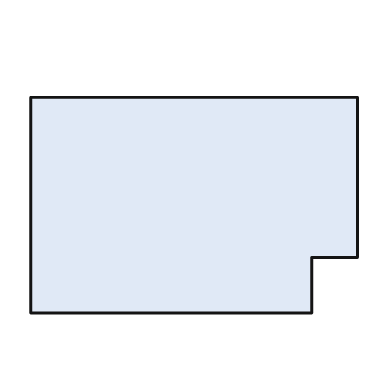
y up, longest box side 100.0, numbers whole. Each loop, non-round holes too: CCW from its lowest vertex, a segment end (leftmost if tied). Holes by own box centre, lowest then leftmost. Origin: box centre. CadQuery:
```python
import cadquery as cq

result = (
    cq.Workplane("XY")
    .moveTo(-50.0, -33.0)
    .lineTo(36.0, -33.0)
    .lineTo(36.0, -16.0)
    .lineTo(50.0, -16.0)
    .lineTo(50.0, 33.0)
    .lineTo(-50.0, 33.0)
    .close()
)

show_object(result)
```